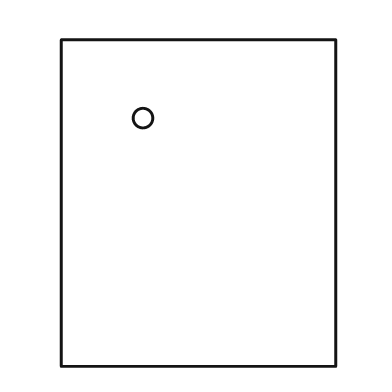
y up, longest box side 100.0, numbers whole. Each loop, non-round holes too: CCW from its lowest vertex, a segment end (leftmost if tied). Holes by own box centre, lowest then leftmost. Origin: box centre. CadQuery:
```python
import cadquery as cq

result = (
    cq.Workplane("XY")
    .moveTo(-42.0, -50.0)
    .lineTo(42.0, -50.0)
    .lineTo(42.0, 50.0)
    .lineTo(-42.0, 50.0)
    .close()
    .moveTo(-17.0, 26.0)
    .circle(3.0)
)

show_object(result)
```